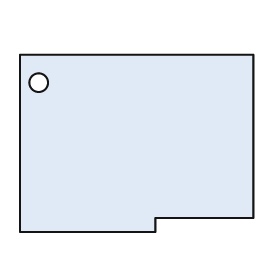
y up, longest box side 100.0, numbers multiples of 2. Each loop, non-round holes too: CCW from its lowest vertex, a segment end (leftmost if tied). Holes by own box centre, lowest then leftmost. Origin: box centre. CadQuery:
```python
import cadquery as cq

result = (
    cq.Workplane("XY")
    .moveTo(-50.0, -38.0)
    .lineTo(8.0, -38.0)
    .lineTo(8.0, -32.0)
    .lineTo(50.0, -32.0)
    .lineTo(50.0, 38.0)
    .lineTo(-50.0, 38.0)
    .close()
    .moveTo(-42.0, 26.0)
    .circle(4.0)
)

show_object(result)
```